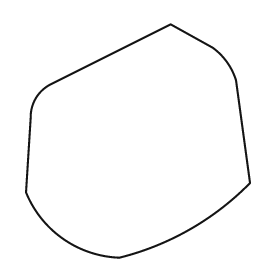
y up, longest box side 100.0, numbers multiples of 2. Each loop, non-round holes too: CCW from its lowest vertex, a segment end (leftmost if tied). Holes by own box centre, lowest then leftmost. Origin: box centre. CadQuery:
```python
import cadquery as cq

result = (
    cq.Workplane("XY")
    .moveTo(-8.0, -50.0)
    .threePointArc((22.0, -38.0), (48.0, -18.0))
    .lineTo(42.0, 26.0)
    .threePointArc((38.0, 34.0), (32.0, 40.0))
    .lineTo(14.0, 50.0)
    .lineTo(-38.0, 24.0)
    .threePointArc((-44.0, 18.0), (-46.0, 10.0))
    .lineTo(-48.0, -22.0)
    .threePointArc((-32.0, -42.0), (-8.0, -50.0))
    .close()
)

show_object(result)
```